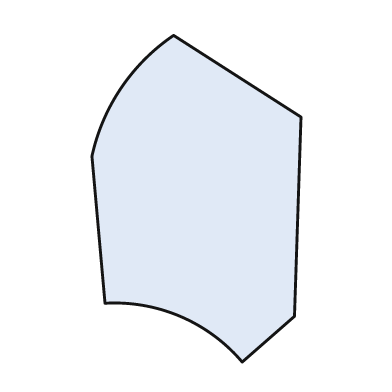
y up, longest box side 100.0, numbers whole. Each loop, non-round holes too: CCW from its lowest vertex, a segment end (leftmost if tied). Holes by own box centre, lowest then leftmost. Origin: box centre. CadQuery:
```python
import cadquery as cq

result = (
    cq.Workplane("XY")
    .moveTo(14.0, -50.0)
    .lineTo(30.0, -36.0)
    .lineTo(32.0, 25.0)
    .lineTo(-7.0, 50.0)
    .threePointArc((-23.0, 34.0), (-32.0, 13.0))
    .lineTo(-28.0, -32.0)
    .threePointArc((-5.0, -36.0), (14.0, -50.0))
    .close()
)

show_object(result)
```